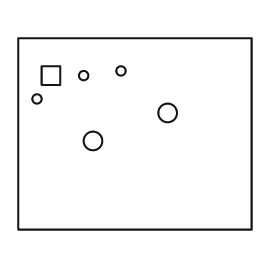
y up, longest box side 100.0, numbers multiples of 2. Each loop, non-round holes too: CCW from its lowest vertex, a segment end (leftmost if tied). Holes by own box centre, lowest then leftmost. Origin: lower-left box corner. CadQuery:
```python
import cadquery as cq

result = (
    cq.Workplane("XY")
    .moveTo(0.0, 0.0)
    .lineTo(100.0, 0.0)
    .lineTo(100.0, 82.0)
    .lineTo(0.0, 82.0)
    .close()
    .moveTo(32.0, 38.0)
    .circle(4.0)
    .moveTo(64.0, 50.0)
    .circle(4.0)
    .moveTo(8.0, 56.0)
    .circle(2.0)
    .moveTo(10.0, 62.0)
    .lineTo(18.0, 62.0)
    .lineTo(18.0, 70.0)
    .lineTo(10.0, 70.0)
    .close()
    .moveTo(28.0, 66.0)
    .circle(2.0)
    .moveTo(44.0, 68.0)
    .circle(2.0)
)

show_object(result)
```